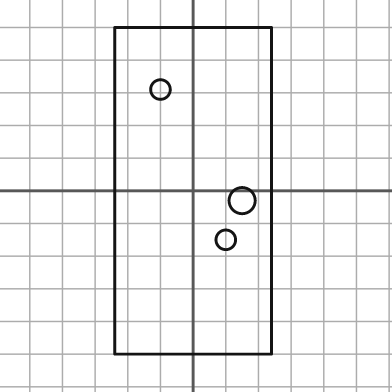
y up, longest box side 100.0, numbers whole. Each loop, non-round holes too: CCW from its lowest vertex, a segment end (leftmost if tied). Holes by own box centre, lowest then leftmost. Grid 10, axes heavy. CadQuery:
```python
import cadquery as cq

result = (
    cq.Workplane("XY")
    .moveTo(-24.0, -50.0)
    .lineTo(24.0, -50.0)
    .lineTo(24.0, 50.0)
    .lineTo(-24.0, 50.0)
    .close()
    .moveTo(10.0, -15.0)
    .circle(3.0)
    .moveTo(15.0, -3.0)
    .circle(4.0)
    .moveTo(-10.0, 31.0)
    .circle(3.0)
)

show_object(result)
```